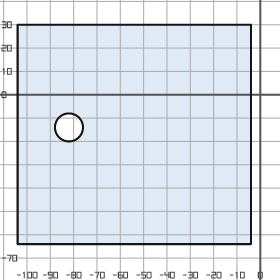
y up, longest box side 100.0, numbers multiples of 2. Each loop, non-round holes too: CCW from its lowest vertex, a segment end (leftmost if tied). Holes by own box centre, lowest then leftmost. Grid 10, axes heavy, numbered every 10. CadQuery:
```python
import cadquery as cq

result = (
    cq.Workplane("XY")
    .moveTo(-104.0, -64.0)
    .lineTo(-4.0, -64.0)
    .lineTo(-4.0, 30.0)
    .lineTo(-104.0, 30.0)
    .close()
    .moveTo(-82.0, -14.0)
    .circle(6.0)
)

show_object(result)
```